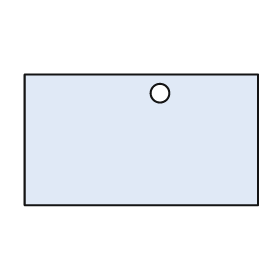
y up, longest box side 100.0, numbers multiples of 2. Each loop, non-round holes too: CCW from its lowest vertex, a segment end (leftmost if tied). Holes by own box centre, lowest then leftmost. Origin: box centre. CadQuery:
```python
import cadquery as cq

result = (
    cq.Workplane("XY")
    .moveTo(-50.0, -28.0)
    .lineTo(50.0, -28.0)
    .lineTo(50.0, 28.0)
    .lineTo(-50.0, 28.0)
    .close()
    .moveTo(8.0, 20.0)
    .circle(4.0)
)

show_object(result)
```